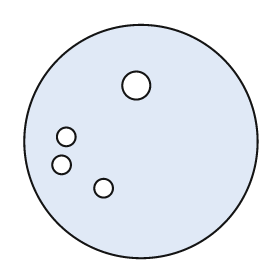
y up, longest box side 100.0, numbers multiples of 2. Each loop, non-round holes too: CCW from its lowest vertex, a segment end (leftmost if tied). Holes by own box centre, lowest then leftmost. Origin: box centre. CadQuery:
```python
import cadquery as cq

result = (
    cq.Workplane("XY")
    .moveTo(0.0, 0.0)
    .circle(50.0)
    .moveTo(-16.0, -20.0)
    .circle(4.0)
    .moveTo(-34.0, -10.0)
    .circle(4.0)
    .moveTo(-32.0, 2.0)
    .circle(4.0)
    .moveTo(-2.0, 24.0)
    .circle(6.0)
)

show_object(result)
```